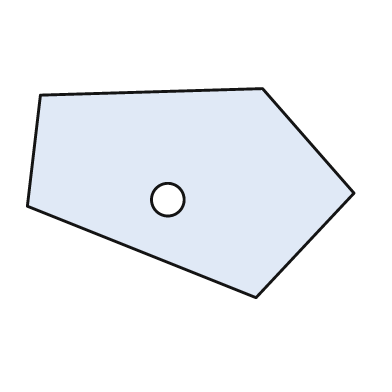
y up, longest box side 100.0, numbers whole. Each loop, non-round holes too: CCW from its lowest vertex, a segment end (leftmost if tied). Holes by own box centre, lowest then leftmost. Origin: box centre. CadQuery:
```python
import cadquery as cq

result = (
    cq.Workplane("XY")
    .moveTo(20.0, -32.0)
    .lineTo(50.0, 0.0)
    .lineTo(22.0, 32.0)
    .lineTo(-46.0, 30.0)
    .lineTo(-50.0, -4.0)
    .close()
    .moveTo(-7.0, -2.0)
    .circle(5.0)
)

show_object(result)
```